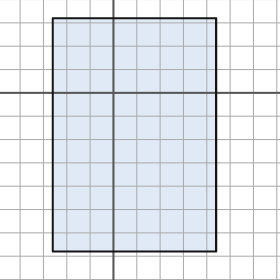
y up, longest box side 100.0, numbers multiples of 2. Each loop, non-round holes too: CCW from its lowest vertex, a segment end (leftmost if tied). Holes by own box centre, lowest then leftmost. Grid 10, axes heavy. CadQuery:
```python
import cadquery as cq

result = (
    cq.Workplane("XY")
    .moveTo(-26.0, -68.0)
    .lineTo(44.0, -68.0)
    .lineTo(44.0, 32.0)
    .lineTo(-26.0, 32.0)
    .close()
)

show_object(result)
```